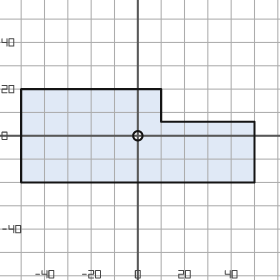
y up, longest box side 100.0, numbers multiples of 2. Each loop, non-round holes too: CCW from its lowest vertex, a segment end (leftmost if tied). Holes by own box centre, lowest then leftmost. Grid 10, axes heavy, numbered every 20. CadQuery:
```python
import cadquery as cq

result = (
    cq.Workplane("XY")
    .moveTo(-50.0, -20.0)
    .lineTo(50.0, -20.0)
    .lineTo(50.0, 6.0)
    .lineTo(10.0, 6.0)
    .lineTo(10.0, 20.0)
    .lineTo(-50.0, 20.0)
    .close()
    .moveTo(0.0, 0.0)
    .circle(2.0)
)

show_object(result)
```